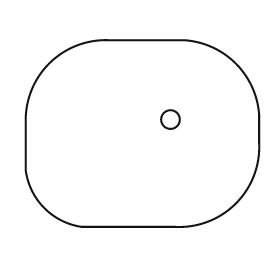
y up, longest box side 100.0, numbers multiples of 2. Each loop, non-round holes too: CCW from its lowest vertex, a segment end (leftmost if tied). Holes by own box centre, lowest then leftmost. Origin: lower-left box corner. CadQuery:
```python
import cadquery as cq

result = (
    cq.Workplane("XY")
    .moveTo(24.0, 0.0)
    .lineTo(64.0, 0.0)
    .threePointArc((90.0, 10.0), (100.0, 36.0))
    .lineTo(100.0, 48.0)
    .threePointArc((90.0, 70.0), (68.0, 80.0))
    .lineTo(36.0, 80.0)
    .threePointArc((10.0, 70.0), (0.0, 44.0))
    .lineTo(0.0, 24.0)
    .threePointArc((8.0, 8.0), (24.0, 0.0))
    .close()
    .moveTo(62.0, 46.0)
    .circle(4.0)
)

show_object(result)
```